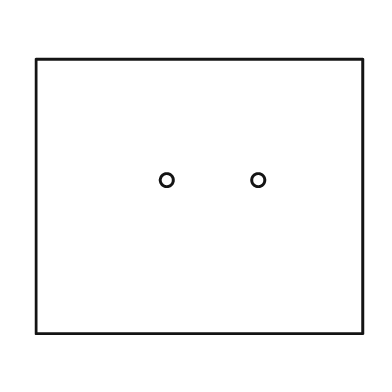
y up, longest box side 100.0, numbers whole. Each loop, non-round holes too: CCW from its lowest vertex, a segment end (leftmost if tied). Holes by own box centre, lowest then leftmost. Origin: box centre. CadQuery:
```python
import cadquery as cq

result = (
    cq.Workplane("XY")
    .moveTo(-50.0, -42.0)
    .lineTo(50.0, -42.0)
    .lineTo(50.0, 42.0)
    .lineTo(-50.0, 42.0)
    .close()
    .moveTo(-10.0, 5.0)
    .circle(2.0)
    .moveTo(18.0, 5.0)
    .circle(2.0)
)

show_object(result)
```